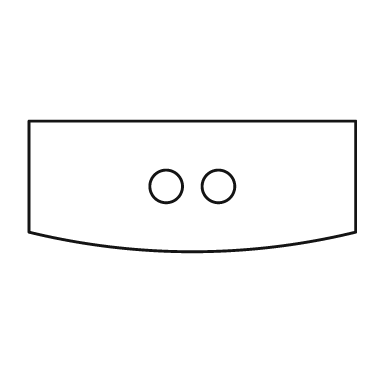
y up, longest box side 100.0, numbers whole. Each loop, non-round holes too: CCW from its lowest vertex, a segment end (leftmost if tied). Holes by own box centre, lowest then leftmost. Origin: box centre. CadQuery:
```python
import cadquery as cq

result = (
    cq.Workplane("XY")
    .moveTo(-50.0, -14.0)
    .threePointArc((0.0, -20.0), (50.0, -14.0))
    .lineTo(50.0, 20.0)
    .lineTo(-50.0, 20.0)
    .close()
    .moveTo(-8.0, 0.0)
    .circle(5.0)
    .moveTo(8.0, 0.0)
    .circle(5.0)
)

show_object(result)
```